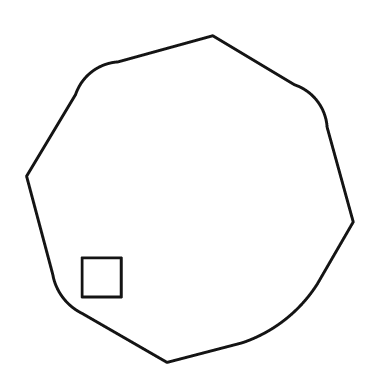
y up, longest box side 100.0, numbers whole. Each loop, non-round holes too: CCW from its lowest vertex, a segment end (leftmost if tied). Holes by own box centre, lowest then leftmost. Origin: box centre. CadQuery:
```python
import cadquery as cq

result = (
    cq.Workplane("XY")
    .moveTo(-7.0, -50.0)
    .lineTo(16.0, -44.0)
    .threePointArc((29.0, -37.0), (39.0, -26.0))
    .lineTo(50.0, -7.0)
    .lineTo(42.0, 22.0)
    .threePointArc((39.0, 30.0), (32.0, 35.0))
    .lineTo(7.0, 50.0)
    .lineTo(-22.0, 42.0)
    .threePointArc((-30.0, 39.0), (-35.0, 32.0))
    .lineTo(-50.0, 7.0)
    .lineTo(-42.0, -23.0)
    .threePointArc((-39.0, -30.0), (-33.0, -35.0))
    .close()
    .moveTo(-33.0, -30.0)
    .lineTo(-21.0, -30.0)
    .lineTo(-21.0, -18.0)
    .lineTo(-33.0, -18.0)
    .close()
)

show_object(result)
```